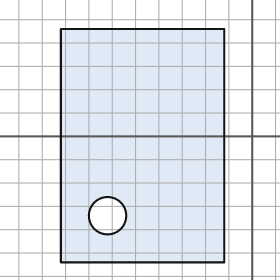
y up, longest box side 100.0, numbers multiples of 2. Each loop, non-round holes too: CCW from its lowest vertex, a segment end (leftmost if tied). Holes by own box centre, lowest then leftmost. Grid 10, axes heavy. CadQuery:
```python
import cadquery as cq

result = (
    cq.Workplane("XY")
    .moveTo(-82.0, -54.0)
    .lineTo(-12.0, -54.0)
    .lineTo(-12.0, 46.0)
    .lineTo(-82.0, 46.0)
    .close()
    .moveTo(-62.0, -34.0)
    .circle(8.0)
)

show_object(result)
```